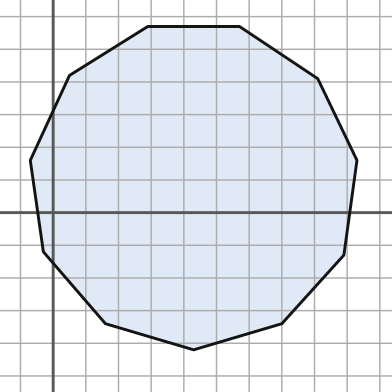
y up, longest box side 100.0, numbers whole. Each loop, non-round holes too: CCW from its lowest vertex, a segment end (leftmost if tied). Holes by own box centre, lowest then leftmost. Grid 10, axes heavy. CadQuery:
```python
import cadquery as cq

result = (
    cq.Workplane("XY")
    .moveTo(43.0, -42.0)
    .lineTo(70.0, -34.0)
    .lineTo(89.0, -13.0)
    .lineTo(93.0, 16.0)
    .lineTo(81.0, 41.0)
    .lineTo(57.0, 57.0)
    .lineTo(29.0, 57.0)
    .lineTo(5.0, 42.0)
    .lineTo(-7.0, 16.0)
    .lineTo(-3.0, -12.0)
    .lineTo(16.0, -34.0)
    .close()
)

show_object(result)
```